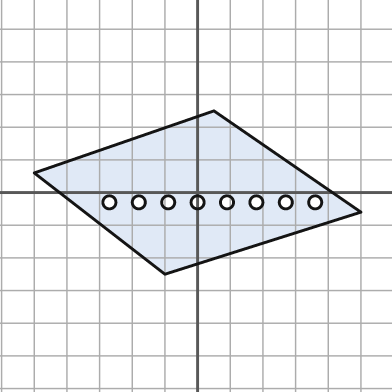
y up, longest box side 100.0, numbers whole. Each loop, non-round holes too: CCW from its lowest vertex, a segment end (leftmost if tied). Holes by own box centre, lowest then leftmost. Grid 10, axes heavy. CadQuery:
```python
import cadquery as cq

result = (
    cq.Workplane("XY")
    .moveTo(-10.0, -25.0)
    .lineTo(50.0, -6.0)
    .lineTo(5.0, 25.0)
    .lineTo(-50.0, 6.0)
    .close()
    .moveTo(-27.0, -3.0)
    .circle(2.0)
    .moveTo(-18.0, -3.0)
    .circle(2.0)
    .moveTo(-9.0, -3.0)
    .circle(2.0)
    .moveTo(0.0, -3.0)
    .circle(2.0)
    .moveTo(9.0, -3.0)
    .circle(2.0)
    .moveTo(18.0, -3.0)
    .circle(2.0)
    .moveTo(27.0, -3.0)
    .circle(2.0)
    .moveTo(36.0, -3.0)
    .circle(2.0)
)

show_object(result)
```